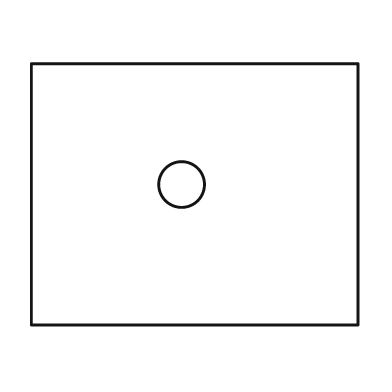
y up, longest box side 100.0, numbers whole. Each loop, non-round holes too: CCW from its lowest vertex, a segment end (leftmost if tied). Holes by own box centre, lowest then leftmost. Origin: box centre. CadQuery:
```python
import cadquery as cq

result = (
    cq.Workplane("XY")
    .moveTo(-50.0, -40.0)
    .lineTo(50.0, -40.0)
    .lineTo(50.0, 40.0)
    .lineTo(-50.0, 40.0)
    .close()
    .moveTo(-4.0, 3.0)
    .circle(7.0)
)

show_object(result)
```